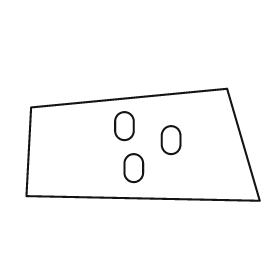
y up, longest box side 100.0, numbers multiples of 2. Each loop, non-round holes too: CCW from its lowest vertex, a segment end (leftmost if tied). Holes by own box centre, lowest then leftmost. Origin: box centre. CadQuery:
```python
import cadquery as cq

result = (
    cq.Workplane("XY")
    .moveTo(50.0, -24.0)
    .lineTo(36.0, 24.0)
    .lineTo(-48.0, 16.0)
    .lineTo(-50.0, -22.0)
    .close()
    .moveTo(-8.0, -12.0)
    .threePointArc((-4.0, -16.0), (0.0, -12.0))
    .lineTo(0.0, -8.0)
    .threePointArc((-4.0, -4.0), (-8.0, -8.0))
    .close()
    .moveTo(8.0, 0.0)
    .threePointArc((12.0, -4.0), (16.0, 0.0))
    .lineTo(16.0, 4.0)
    .threePointArc((12.0, 8.0), (8.0, 4.0))
    .close()
    .moveTo(-12.0, 6.0)
    .threePointArc((-8.0, 2.0), (-4.0, 6.0))
    .lineTo(-4.0, 10.0)
    .threePointArc((-8.0, 14.0), (-12.0, 10.0))
    .close()
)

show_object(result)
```